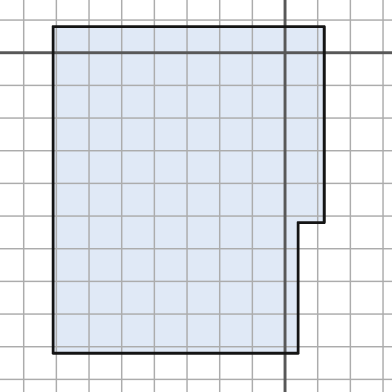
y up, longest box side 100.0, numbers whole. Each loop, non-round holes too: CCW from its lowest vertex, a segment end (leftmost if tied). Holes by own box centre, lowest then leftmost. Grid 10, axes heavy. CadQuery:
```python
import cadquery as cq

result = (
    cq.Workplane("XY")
    .moveTo(-71.0, -92.0)
    .lineTo(4.0, -92.0)
    .lineTo(4.0, -52.0)
    .lineTo(12.0, -52.0)
    .lineTo(12.0, 8.0)
    .lineTo(-71.0, 8.0)
    .close()
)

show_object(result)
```